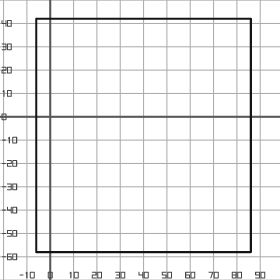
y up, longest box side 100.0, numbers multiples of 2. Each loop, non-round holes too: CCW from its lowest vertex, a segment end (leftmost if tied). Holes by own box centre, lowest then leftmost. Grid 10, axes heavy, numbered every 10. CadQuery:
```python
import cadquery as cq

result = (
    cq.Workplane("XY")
    .moveTo(-6.0, -58.0)
    .lineTo(86.0, -58.0)
    .lineTo(86.0, 42.0)
    .lineTo(-6.0, 42.0)
    .close()
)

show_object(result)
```